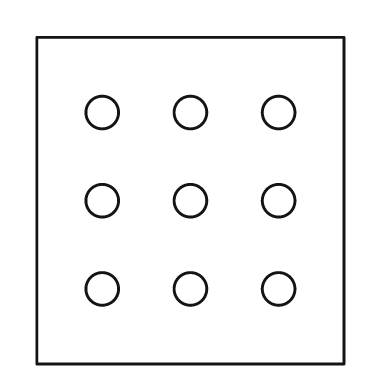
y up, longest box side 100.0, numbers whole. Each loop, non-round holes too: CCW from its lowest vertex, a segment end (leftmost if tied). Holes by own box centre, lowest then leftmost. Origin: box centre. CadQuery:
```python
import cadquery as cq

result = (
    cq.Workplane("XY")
    .moveTo(-47.0, -50.0)
    .lineTo(47.0, -50.0)
    .lineTo(47.0, 50.0)
    .lineTo(-47.0, 50.0)
    .close()
    .moveTo(-27.0, -27.0)
    .circle(5.0)
    .moveTo(0.0, -27.0)
    .circle(5.0)
    .moveTo(27.0, -27.0)
    .circle(5.0)
    .moveTo(-27.0, 0.0)
    .circle(5.0)
    .moveTo(0.0, 0.0)
    .circle(5.0)
    .moveTo(27.0, 0.0)
    .circle(5.0)
    .moveTo(-27.0, 27.0)
    .circle(5.0)
    .moveTo(0.0, 27.0)
    .circle(5.0)
    .moveTo(27.0, 27.0)
    .circle(5.0)
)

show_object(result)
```